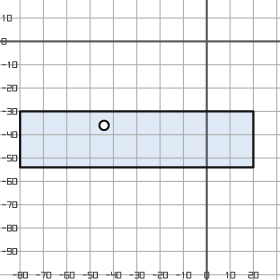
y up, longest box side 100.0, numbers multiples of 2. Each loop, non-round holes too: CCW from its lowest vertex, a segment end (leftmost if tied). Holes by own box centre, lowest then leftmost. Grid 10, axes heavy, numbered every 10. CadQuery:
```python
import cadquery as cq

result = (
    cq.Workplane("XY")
    .moveTo(-80.0, -54.0)
    .lineTo(20.0, -54.0)
    .lineTo(20.0, -30.0)
    .lineTo(-80.0, -30.0)
    .close()
    .moveTo(-44.0, -36.0)
    .circle(2.0)
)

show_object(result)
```